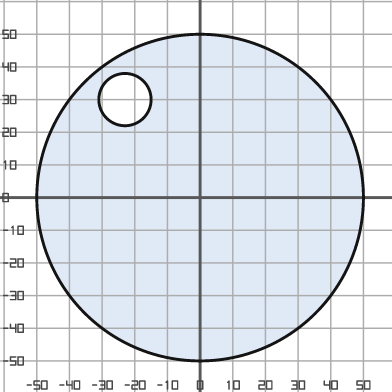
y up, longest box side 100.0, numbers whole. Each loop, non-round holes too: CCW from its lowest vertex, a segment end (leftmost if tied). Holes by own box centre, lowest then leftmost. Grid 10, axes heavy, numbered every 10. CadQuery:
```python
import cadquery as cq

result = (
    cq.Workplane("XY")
    .moveTo(0.0, 0.0)
    .circle(50.0)
    .moveTo(-23.0, 30.0)
    .circle(8.0)
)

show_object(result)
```